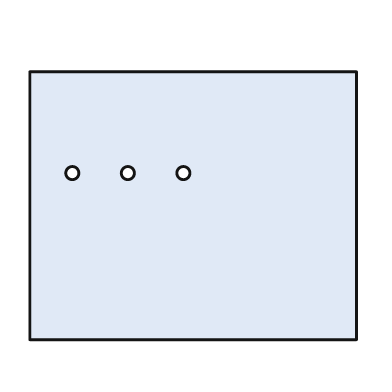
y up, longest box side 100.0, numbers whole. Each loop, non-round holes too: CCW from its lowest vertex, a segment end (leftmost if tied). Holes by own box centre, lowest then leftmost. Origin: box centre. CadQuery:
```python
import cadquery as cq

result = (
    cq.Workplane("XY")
    .moveTo(-50.0, -41.0)
    .lineTo(50.0, -41.0)
    .lineTo(50.0, 41.0)
    .lineTo(-50.0, 41.0)
    .close()
    .moveTo(-37.0, 10.0)
    .circle(2.0)
    .moveTo(-20.0, 10.0)
    .circle(2.0)
    .moveTo(-3.0, 10.0)
    .circle(2.0)
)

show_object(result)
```